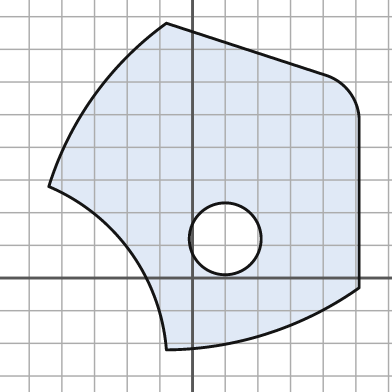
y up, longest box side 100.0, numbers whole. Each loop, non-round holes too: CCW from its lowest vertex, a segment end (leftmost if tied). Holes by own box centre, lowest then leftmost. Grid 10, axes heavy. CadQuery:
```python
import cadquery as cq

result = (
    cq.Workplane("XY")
    .moveTo(-8.0, -22.0)
    .threePointArc((23.0, -17.0), (51.0, -3.0))
    .lineTo(51.0, 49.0)
    .threePointArc((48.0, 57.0), (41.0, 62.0))
    .lineTo(-8.0, 78.0)
    .threePointArc((-30.0, 56.0), (-44.0, 28.0))
    .threePointArc((-19.0, 8.0), (-8.0, -22.0))
    .close()
    .moveTo(10.0, 12.0)
    .circle(11.0)
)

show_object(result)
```